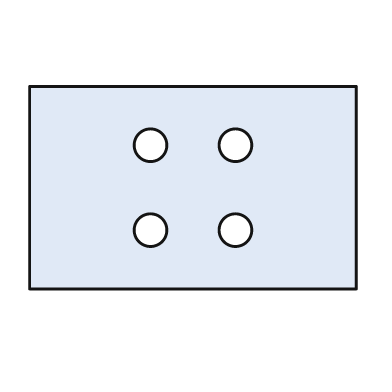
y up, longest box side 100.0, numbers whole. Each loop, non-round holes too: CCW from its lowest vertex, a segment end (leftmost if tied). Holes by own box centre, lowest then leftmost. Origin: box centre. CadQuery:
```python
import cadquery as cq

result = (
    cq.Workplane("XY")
    .moveTo(-50.0, -31.0)
    .lineTo(50.0, -31.0)
    .lineTo(50.0, 31.0)
    .lineTo(-50.0, 31.0)
    .close()
    .moveTo(-13.0, -13.0)
    .circle(5.0)
    .moveTo(13.0, -13.0)
    .circle(5.0)
    .moveTo(-13.0, 13.0)
    .circle(5.0)
    .moveTo(13.0, 13.0)
    .circle(5.0)
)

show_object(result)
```